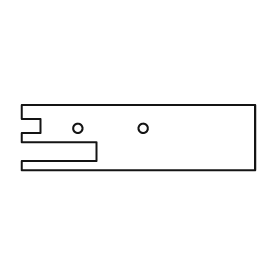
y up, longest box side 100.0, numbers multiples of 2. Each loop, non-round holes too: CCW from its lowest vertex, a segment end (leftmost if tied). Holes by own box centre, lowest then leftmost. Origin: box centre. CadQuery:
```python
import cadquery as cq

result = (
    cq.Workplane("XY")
    .moveTo(-50.0, -14.0)
    .lineTo(50.0, -14.0)
    .lineTo(50.0, 14.0)
    .lineTo(-50.0, 14.0)
    .lineTo(-50.0, 8.0)
    .lineTo(-42.0, 8.0)
    .lineTo(-42.0, 2.0)
    .lineTo(-50.0, 2.0)
    .lineTo(-50.0, -2.0)
    .lineTo(-18.0, -2.0)
    .lineTo(-18.0, -10.0)
    .lineTo(-50.0, -10.0)
    .close()
    .moveTo(-26.0, 4.0)
    .circle(2.0)
    .moveTo(2.0, 4.0)
    .circle(2.0)
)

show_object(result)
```